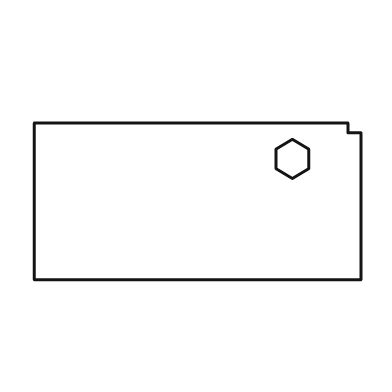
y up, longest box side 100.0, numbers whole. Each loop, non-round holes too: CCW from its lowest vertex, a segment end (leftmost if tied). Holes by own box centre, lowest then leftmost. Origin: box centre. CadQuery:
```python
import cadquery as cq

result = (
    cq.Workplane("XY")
    .moveTo(-50.0, -24.0)
    .lineTo(50.0, -24.0)
    .lineTo(50.0, 21.0)
    .lineTo(46.0, 21.0)
    .lineTo(46.0, 24.0)
    .lineTo(-50.0, 24.0)
    .close()
    .moveTo(29.0, 7.0)
    .lineTo(34.0, 10.0)
    .lineTo(34.0, 16.0)
    .lineTo(29.0, 19.0)
    .lineTo(24.0, 16.0)
    .lineTo(24.0, 10.0)
    .close()
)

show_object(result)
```